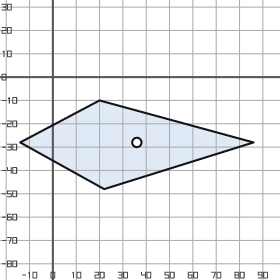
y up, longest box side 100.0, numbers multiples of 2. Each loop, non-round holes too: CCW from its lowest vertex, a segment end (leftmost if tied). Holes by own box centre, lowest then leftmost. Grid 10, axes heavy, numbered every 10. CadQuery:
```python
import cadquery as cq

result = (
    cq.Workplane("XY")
    .moveTo(22.0, -48.0)
    .lineTo(86.0, -28.0)
    .lineTo(20.0, -10.0)
    .lineTo(-14.0, -28.0)
    .close()
    .moveTo(36.0, -28.0)
    .circle(2.0)
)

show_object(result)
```